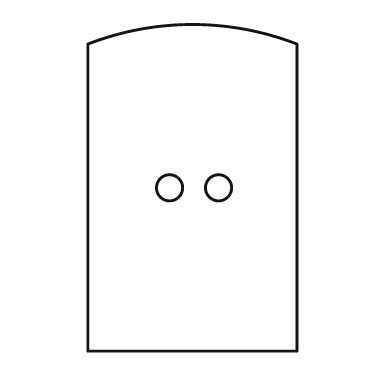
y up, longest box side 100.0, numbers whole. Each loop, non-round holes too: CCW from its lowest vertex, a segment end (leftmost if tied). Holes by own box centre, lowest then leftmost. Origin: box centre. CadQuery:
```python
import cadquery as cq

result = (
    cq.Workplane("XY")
    .moveTo(-32.0, -50.0)
    .lineTo(32.0, -50.0)
    .lineTo(32.0, 44.0)
    .threePointArc((0.0, 50.0), (-32.0, 44.0))
    .close()
    .moveTo(-7.0, 0.0)
    .circle(4.0)
    .moveTo(8.0, 0.0)
    .circle(4.0)
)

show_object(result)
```